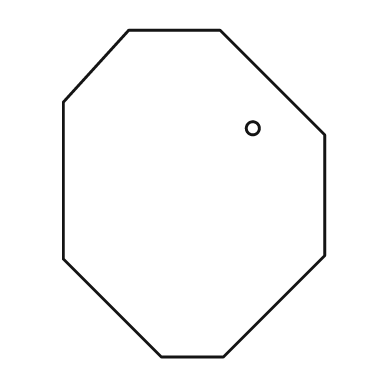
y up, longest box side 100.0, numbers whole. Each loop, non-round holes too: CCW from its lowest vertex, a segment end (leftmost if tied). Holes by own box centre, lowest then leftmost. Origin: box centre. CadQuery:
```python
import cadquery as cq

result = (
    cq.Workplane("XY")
    .moveTo(-10.0, -50.0)
    .lineTo(9.0, -50.0)
    .lineTo(40.0, -19.0)
    .lineTo(40.0, 18.0)
    .lineTo(8.0, 50.0)
    .lineTo(-20.0, 50.0)
    .lineTo(-40.0, 28.0)
    .lineTo(-40.0, -20.0)
    .close()
    .moveTo(18.0, 20.0)
    .circle(2.0)
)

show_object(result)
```